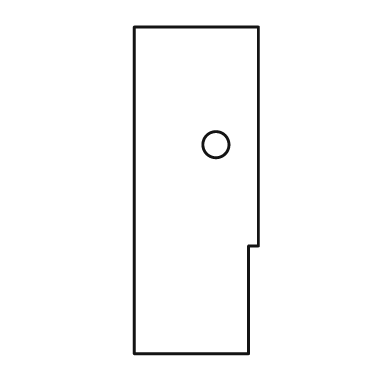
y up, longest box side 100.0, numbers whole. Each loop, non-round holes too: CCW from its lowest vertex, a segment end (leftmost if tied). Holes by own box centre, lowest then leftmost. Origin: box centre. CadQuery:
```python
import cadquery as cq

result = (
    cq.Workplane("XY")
    .moveTo(-19.0, -50.0)
    .lineTo(16.0, -50.0)
    .lineTo(16.0, -17.0)
    .lineTo(19.0, -17.0)
    .lineTo(19.0, 50.0)
    .lineTo(-19.0, 50.0)
    .close()
    .moveTo(6.0, 14.0)
    .circle(4.0)
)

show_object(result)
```